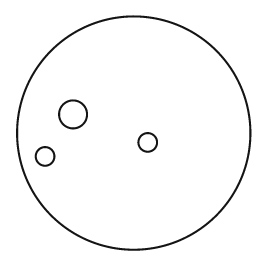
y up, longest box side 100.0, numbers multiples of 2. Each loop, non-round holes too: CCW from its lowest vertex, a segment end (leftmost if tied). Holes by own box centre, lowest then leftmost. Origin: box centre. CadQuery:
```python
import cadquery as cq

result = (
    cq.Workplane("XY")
    .moveTo(0.0, 0.0)
    .circle(50.0)
    .moveTo(-38.0, -10.0)
    .circle(4.0)
    .moveTo(6.0, -4.0)
    .circle(4.0)
    .moveTo(-26.0, 8.0)
    .circle(6.0)
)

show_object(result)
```